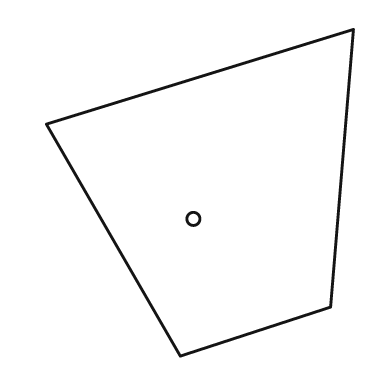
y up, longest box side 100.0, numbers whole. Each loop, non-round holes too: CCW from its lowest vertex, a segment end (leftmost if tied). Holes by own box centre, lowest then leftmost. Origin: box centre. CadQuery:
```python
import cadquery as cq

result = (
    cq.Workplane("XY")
    .moveTo(-6.0, -50.0)
    .lineTo(40.0, -35.0)
    .lineTo(47.0, 50.0)
    .lineTo(-47.0, 21.0)
    .close()
    .moveTo(-2.0, -8.0)
    .circle(2.0)
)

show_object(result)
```